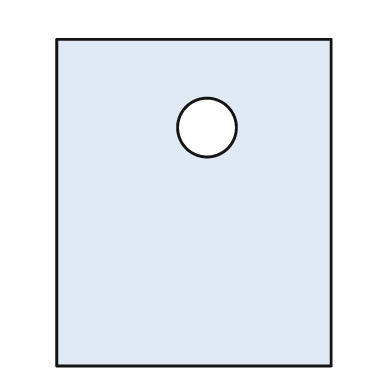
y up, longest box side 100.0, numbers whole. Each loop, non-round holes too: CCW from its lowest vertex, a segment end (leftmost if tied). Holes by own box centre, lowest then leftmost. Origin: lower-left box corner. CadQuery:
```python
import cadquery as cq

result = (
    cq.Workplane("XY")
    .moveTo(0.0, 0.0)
    .lineTo(84.0, 0.0)
    .lineTo(84.0, 100.0)
    .lineTo(0.0, 100.0)
    .close()
    .moveTo(46.0, 73.0)
    .circle(9.0)
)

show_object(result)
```